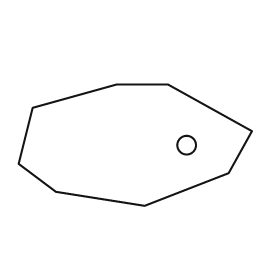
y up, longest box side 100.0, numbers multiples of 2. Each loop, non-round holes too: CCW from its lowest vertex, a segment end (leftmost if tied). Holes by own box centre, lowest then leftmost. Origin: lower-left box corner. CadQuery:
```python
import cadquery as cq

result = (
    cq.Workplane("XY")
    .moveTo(54.0, 0.0)
    .lineTo(90.0, 14.0)
    .lineTo(100.0, 32.0)
    .lineTo(64.0, 52.0)
    .lineTo(42.0, 52.0)
    .lineTo(6.0, 42.0)
    .lineTo(0.0, 18.0)
    .lineTo(16.0, 6.0)
    .close()
    .moveTo(72.0, 26.0)
    .circle(4.0)
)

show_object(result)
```